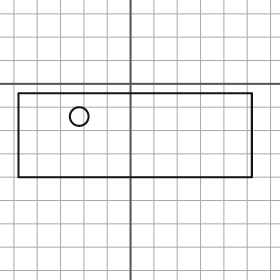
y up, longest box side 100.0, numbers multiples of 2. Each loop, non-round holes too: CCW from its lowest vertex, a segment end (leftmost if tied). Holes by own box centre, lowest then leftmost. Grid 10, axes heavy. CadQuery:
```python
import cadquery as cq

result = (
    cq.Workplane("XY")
    .moveTo(-48.0, -40.0)
    .lineTo(52.0, -40.0)
    .lineTo(52.0, -4.0)
    .lineTo(-48.0, -4.0)
    .close()
    .moveTo(-22.0, -14.0)
    .circle(4.0)
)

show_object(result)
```